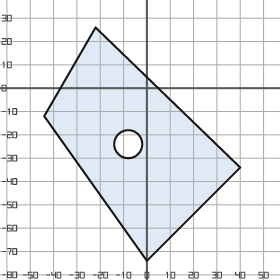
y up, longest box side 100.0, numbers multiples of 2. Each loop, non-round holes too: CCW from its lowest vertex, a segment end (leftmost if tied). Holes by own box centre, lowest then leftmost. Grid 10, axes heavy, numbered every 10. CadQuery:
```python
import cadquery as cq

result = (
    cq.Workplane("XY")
    .moveTo(0.0, -74.0)
    .lineTo(40.0, -34.0)
    .lineTo(-22.0, 26.0)
    .lineTo(-44.0, -12.0)
    .close()
    .moveTo(-8.0, -24.0)
    .circle(6.0)
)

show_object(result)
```